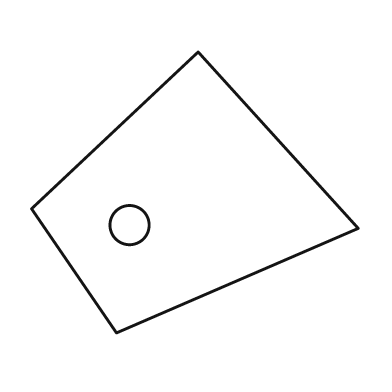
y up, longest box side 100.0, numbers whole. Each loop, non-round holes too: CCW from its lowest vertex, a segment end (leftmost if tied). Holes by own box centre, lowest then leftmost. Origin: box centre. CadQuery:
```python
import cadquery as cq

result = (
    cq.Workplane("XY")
    .moveTo(-24.0, -43.0)
    .lineTo(50.0, -11.0)
    .lineTo(1.0, 43.0)
    .lineTo(-50.0, -5.0)
    .close()
    .moveTo(-20.0, -10.0)
    .circle(6.0)
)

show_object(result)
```